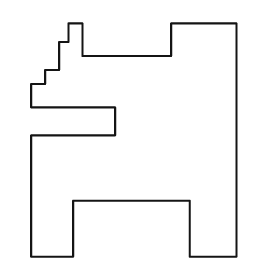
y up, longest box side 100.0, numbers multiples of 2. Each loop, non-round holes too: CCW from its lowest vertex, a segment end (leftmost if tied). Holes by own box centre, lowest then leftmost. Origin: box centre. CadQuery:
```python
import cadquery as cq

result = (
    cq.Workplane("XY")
    .moveTo(-44.0, -50.0)
    .lineTo(-26.0, -50.0)
    .lineTo(-26.0, -26.0)
    .lineTo(24.0, -26.0)
    .lineTo(24.0, -50.0)
    .lineTo(44.0, -50.0)
    .lineTo(44.0, 50.0)
    .lineTo(16.0, 50.0)
    .lineTo(16.0, 36.0)
    .lineTo(-22.0, 36.0)
    .lineTo(-22.0, 50.0)
    .lineTo(-28.0, 50.0)
    .lineTo(-28.0, 42.0)
    .lineTo(-32.0, 42.0)
    .lineTo(-32.0, 30.0)
    .lineTo(-38.0, 30.0)
    .lineTo(-38.0, 24.0)
    .lineTo(-44.0, 24.0)
    .lineTo(-44.0, 14.0)
    .lineTo(-8.0, 14.0)
    .lineTo(-8.0, 2.0)
    .lineTo(-44.0, 2.0)
    .close()
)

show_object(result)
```